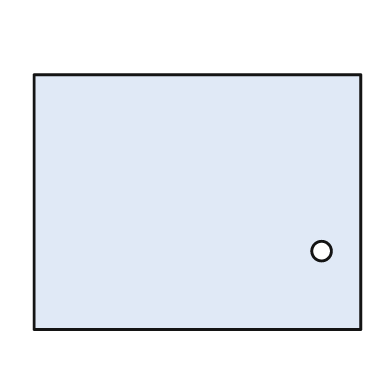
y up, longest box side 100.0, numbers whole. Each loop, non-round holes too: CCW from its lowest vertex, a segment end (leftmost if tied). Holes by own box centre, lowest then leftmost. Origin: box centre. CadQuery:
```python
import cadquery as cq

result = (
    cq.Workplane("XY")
    .moveTo(-50.0, -39.0)
    .lineTo(50.0, -39.0)
    .lineTo(50.0, 39.0)
    .lineTo(-50.0, 39.0)
    .close()
    .moveTo(38.0, -15.0)
    .circle(3.0)
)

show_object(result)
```